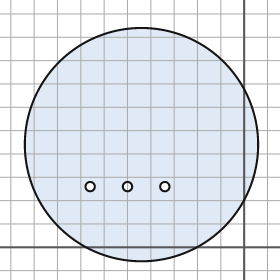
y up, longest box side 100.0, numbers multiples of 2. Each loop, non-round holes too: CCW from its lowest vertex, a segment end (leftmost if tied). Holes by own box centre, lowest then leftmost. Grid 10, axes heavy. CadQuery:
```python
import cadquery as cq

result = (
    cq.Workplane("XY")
    .moveTo(-44.0, 44.0)
    .circle(50.0)
    .moveTo(-66.0, 26.0)
    .circle(2.0)
    .moveTo(-50.0, 26.0)
    .circle(2.0)
    .moveTo(-34.0, 26.0)
    .circle(2.0)
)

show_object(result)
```